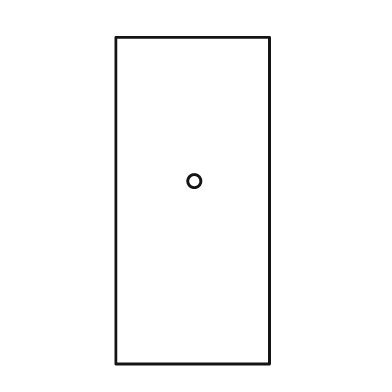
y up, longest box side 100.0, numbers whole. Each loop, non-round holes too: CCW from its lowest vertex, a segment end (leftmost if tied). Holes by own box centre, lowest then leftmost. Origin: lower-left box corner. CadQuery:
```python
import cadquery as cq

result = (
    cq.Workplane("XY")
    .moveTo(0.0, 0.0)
    .lineTo(47.0, 0.0)
    .lineTo(47.0, 100.0)
    .lineTo(0.0, 100.0)
    .close()
    .moveTo(24.0, 56.0)
    .circle(2.0)
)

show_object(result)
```